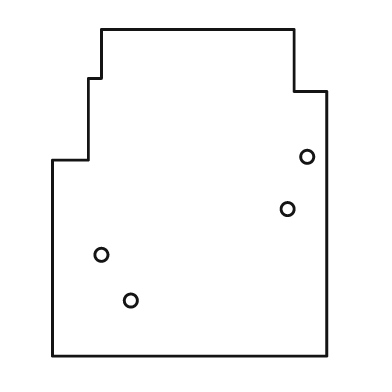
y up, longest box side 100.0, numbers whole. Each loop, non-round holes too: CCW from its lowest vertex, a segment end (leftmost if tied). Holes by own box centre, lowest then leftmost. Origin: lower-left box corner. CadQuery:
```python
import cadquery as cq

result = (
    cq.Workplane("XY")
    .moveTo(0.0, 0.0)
    .lineTo(84.0, 0.0)
    .lineTo(84.0, 81.0)
    .lineTo(74.0, 81.0)
    .lineTo(74.0, 100.0)
    .lineTo(15.0, 100.0)
    .lineTo(15.0, 85.0)
    .lineTo(11.0, 85.0)
    .lineTo(11.0, 60.0)
    .lineTo(0.0, 60.0)
    .close()
    .moveTo(24.0, 17.0)
    .circle(2.0)
    .moveTo(15.0, 31.0)
    .circle(2.0)
    .moveTo(72.0, 45.0)
    .circle(2.0)
    .moveTo(78.0, 61.0)
    .circle(2.0)
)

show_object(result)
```